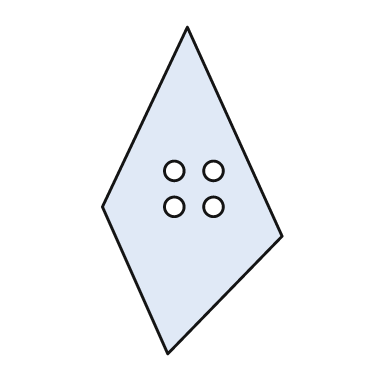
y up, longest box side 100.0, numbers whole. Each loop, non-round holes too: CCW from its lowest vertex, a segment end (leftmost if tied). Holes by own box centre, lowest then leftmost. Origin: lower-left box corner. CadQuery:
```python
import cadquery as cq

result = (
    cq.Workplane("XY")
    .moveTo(20.0, 0.0)
    .lineTo(55.0, 36.0)
    .lineTo(26.0, 100.0)
    .lineTo(0.0, 45.0)
    .close()
    .moveTo(22.0, 45.0)
    .circle(3.0)
    .moveTo(34.0, 45.0)
    .circle(3.0)
    .moveTo(22.0, 56.0)
    .circle(3.0)
    .moveTo(34.0, 56.0)
    .circle(3.0)
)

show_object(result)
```